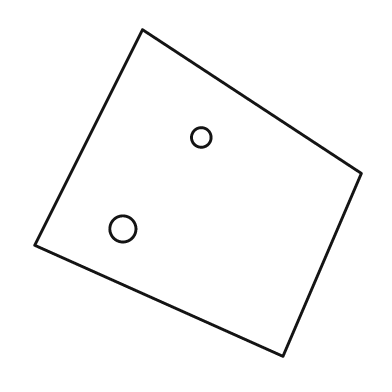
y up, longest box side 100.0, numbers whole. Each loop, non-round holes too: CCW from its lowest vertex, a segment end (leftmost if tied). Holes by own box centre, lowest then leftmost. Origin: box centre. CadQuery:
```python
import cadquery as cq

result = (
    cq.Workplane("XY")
    .moveTo(26.0, -50.0)
    .lineTo(50.0, 6.0)
    .lineTo(-17.0, 50.0)
    .lineTo(-50.0, -16.0)
    .close()
    .moveTo(-23.0, -11.0)
    .circle(4.0)
    .moveTo(1.0, 17.0)
    .circle(3.0)
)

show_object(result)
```